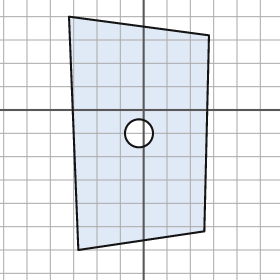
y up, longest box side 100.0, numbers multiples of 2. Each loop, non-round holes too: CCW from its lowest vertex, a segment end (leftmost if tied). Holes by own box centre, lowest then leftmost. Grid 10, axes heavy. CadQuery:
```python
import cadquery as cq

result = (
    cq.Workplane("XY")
    .moveTo(-28.0, -60.0)
    .lineTo(26.0, -52.0)
    .lineTo(28.0, 32.0)
    .lineTo(-32.0, 40.0)
    .close()
    .moveTo(-2.0, -10.0)
    .circle(6.0)
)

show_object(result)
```